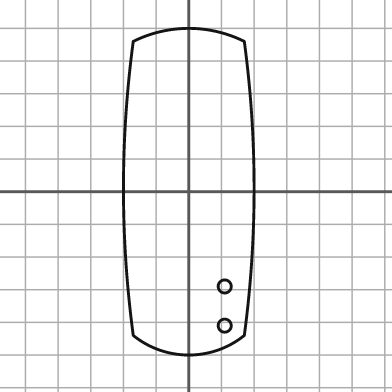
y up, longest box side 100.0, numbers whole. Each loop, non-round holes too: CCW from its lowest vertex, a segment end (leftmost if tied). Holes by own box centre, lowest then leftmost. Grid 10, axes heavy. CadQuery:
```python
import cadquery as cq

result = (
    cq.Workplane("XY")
    .moveTo(-17.0, -44.0)
    .threePointArc((0.0, -50.0), (17.0, -44.0))
    .threePointArc((20.0, 1.0), (17.0, 46.0))
    .threePointArc((0.0, 50.0), (-17.0, 46.0))
    .threePointArc((-20.0, 1.0), (-17.0, -44.0))
    .close()
    .moveTo(11.0, -41.0)
    .circle(2.0)
    .moveTo(11.0, -29.0)
    .circle(2.0)
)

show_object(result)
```